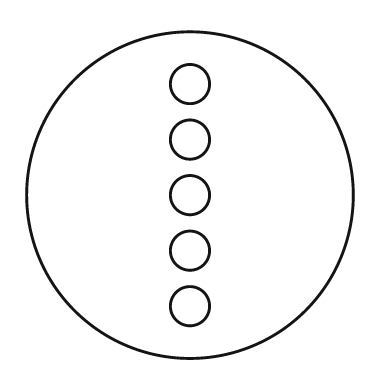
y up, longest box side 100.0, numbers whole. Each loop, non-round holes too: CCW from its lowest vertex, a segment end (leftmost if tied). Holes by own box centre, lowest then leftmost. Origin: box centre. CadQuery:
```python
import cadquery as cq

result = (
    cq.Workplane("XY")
    .moveTo(0.0, 0.0)
    .circle(50.0)
    .moveTo(0.0, -34.0)
    .circle(6.0)
    .moveTo(0.0, -17.0)
    .circle(6.0)
    .moveTo(0.0, 0.0)
    .circle(6.0)
    .moveTo(0.0, 17.0)
    .circle(6.0)
    .moveTo(0.0, 34.0)
    .circle(6.0)
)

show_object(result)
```